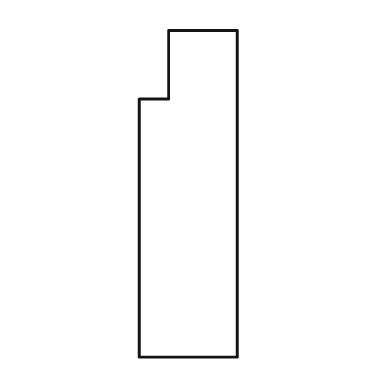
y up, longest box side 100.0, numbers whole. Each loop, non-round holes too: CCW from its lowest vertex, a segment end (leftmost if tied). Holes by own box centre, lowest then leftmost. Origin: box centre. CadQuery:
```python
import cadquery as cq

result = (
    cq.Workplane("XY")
    .moveTo(-15.0, -50.0)
    .lineTo(15.0, -50.0)
    .lineTo(15.0, 50.0)
    .lineTo(-6.0, 50.0)
    .lineTo(-6.0, 29.0)
    .lineTo(-15.0, 29.0)
    .close()
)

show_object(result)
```